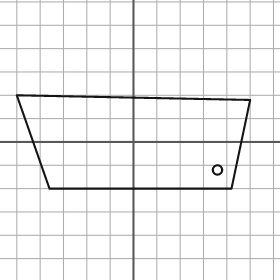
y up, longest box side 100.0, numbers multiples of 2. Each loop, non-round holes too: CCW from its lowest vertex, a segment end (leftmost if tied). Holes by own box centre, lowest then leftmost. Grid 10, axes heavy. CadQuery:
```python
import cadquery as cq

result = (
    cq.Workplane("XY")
    .moveTo(-36.0, -20.0)
    .lineTo(42.0, -20.0)
    .lineTo(50.0, 18.0)
    .lineTo(-50.0, 20.0)
    .close()
    .moveTo(36.0, -12.0)
    .circle(2.0)
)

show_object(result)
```